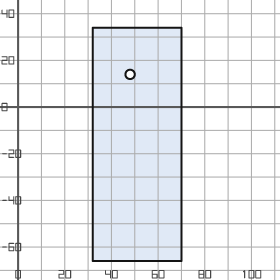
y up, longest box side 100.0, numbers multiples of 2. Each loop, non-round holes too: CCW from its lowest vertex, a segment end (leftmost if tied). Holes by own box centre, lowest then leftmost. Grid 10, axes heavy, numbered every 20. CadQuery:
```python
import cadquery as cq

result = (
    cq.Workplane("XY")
    .moveTo(32.0, -66.0)
    .lineTo(70.0, -66.0)
    .lineTo(70.0, 34.0)
    .lineTo(32.0, 34.0)
    .close()
    .moveTo(48.0, 14.0)
    .circle(2.0)
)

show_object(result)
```